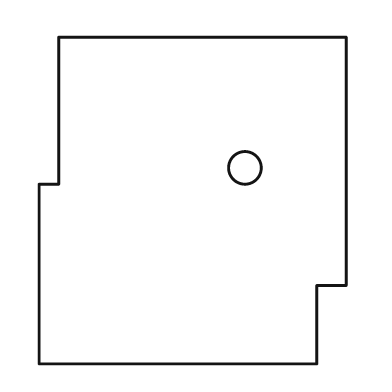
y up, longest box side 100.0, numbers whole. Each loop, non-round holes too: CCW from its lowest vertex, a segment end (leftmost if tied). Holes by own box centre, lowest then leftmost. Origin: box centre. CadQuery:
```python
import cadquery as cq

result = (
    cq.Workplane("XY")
    .moveTo(-47.0, -50.0)
    .lineTo(38.0, -50.0)
    .lineTo(38.0, -26.0)
    .lineTo(47.0, -26.0)
    .lineTo(47.0, 50.0)
    .lineTo(-41.0, 50.0)
    .lineTo(-41.0, 5.0)
    .lineTo(-47.0, 5.0)
    .close()
    .moveTo(16.0, 10.0)
    .circle(5.0)
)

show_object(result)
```